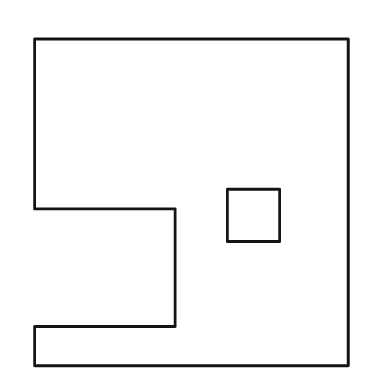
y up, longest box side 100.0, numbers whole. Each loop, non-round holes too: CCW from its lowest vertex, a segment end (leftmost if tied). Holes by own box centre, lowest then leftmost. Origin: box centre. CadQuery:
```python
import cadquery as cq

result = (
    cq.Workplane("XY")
    .moveTo(-48.0, -50.0)
    .lineTo(48.0, -50.0)
    .lineTo(48.0, 50.0)
    .lineTo(-48.0, 50.0)
    .lineTo(-48.0, -2.0)
    .lineTo(-5.0, -2.0)
    .lineTo(-5.0, -38.0)
    .lineTo(-48.0, -38.0)
    .close()
    .moveTo(11.0, -12.0)
    .lineTo(27.0, -12.0)
    .lineTo(27.0, 4.0)
    .lineTo(11.0, 4.0)
    .close()
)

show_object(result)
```